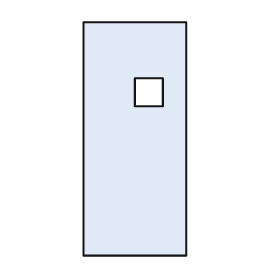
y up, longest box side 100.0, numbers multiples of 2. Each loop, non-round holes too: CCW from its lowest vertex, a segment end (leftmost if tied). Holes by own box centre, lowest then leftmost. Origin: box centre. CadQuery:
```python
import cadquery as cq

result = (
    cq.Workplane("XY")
    .moveTo(-22.0, -50.0)
    .lineTo(22.0, -50.0)
    .lineTo(22.0, 50.0)
    .lineTo(-22.0, 50.0)
    .close()
    .moveTo(0.0, 14.0)
    .lineTo(12.0, 14.0)
    .lineTo(12.0, 26.0)
    .lineTo(0.0, 26.0)
    .close()
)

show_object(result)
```